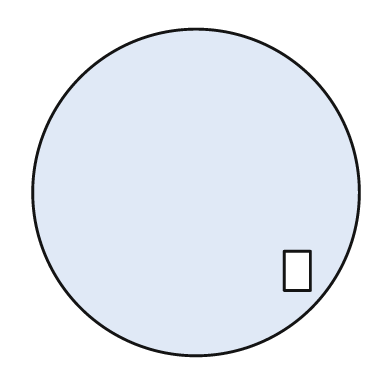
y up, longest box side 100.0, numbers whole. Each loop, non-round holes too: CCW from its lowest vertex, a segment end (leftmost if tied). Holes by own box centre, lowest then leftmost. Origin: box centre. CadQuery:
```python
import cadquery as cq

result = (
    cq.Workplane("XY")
    .moveTo(0.0, 0.0)
    .circle(50.0)
    .moveTo(27.0, -30.0)
    .lineTo(35.0, -30.0)
    .lineTo(35.0, -18.0)
    .lineTo(27.0, -18.0)
    .close()
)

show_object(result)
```